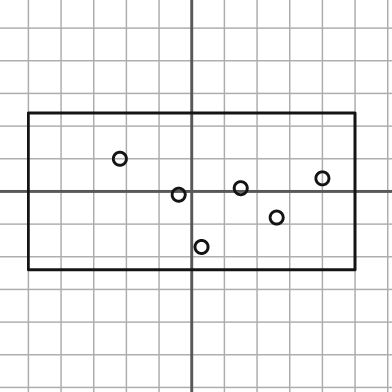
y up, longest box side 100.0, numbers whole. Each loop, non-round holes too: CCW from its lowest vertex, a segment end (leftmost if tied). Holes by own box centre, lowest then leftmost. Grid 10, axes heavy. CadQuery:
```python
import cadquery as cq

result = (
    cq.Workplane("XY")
    .moveTo(-50.0, -24.0)
    .lineTo(50.0, -24.0)
    .lineTo(50.0, 24.0)
    .lineTo(-50.0, 24.0)
    .close()
    .moveTo(3.0, -17.0)
    .circle(2.0)
    .moveTo(26.0, -8.0)
    .circle(2.0)
    .moveTo(-4.0, -1.0)
    .circle(2.0)
    .moveTo(15.0, 1.0)
    .circle(2.0)
    .moveTo(40.0, 4.0)
    .circle(2.0)
    .moveTo(-22.0, 10.0)
    .circle(2.0)
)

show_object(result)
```